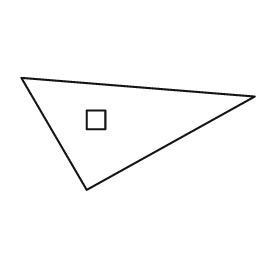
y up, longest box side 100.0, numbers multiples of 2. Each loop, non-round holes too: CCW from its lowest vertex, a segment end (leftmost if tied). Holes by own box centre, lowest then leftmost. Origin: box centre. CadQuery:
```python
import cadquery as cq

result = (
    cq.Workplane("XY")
    .moveTo(-22.0, -24.0)
    .lineTo(50.0, 16.0)
    .lineTo(-50.0, 24.0)
    .close()
    .moveTo(-22.0, 2.0)
    .lineTo(-14.0, 2.0)
    .lineTo(-14.0, 10.0)
    .lineTo(-22.0, 10.0)
    .close()
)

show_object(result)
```